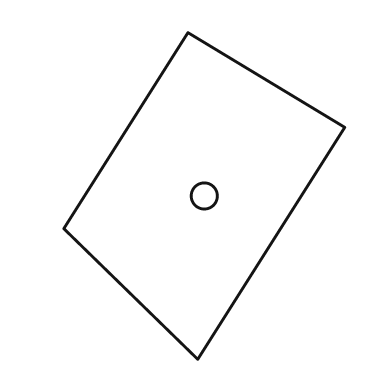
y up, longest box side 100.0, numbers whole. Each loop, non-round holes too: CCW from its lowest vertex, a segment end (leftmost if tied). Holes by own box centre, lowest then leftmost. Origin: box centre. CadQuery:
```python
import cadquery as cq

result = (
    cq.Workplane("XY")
    .moveTo(-2.0, -50.0)
    .lineTo(43.0, 21.0)
    .lineTo(-5.0, 50.0)
    .lineTo(-43.0, -10.0)
    .close()
    .moveTo(0.0, 0.0)
    .circle(4.0)
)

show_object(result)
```